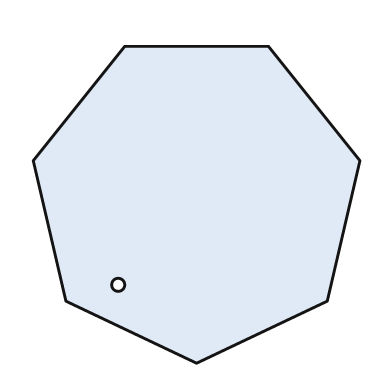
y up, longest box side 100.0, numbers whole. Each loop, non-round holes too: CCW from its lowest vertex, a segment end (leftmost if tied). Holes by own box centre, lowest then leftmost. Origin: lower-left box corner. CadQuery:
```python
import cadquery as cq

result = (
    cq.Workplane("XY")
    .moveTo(50.0, 0.0)
    .lineTo(90.0, 19.0)
    .lineTo(100.0, 62.0)
    .lineTo(72.0, 97.0)
    .lineTo(28.0, 97.0)
    .lineTo(0.0, 62.0)
    .lineTo(10.0, 19.0)
    .close()
    .moveTo(26.0, 24.0)
    .circle(2.0)
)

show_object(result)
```